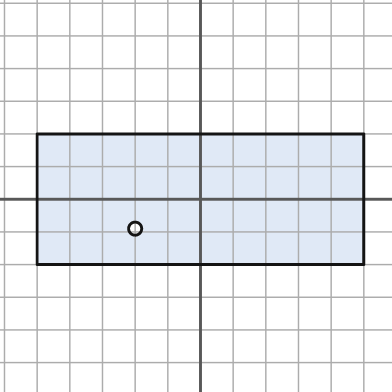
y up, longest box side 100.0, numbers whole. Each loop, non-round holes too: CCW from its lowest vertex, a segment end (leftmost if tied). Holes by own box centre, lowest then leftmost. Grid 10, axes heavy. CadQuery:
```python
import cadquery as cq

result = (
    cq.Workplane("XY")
    .moveTo(-50.0, -20.0)
    .lineTo(50.0, -20.0)
    .lineTo(50.0, 20.0)
    .lineTo(-50.0, 20.0)
    .close()
    .moveTo(-20.0, -9.0)
    .circle(2.0)
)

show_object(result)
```